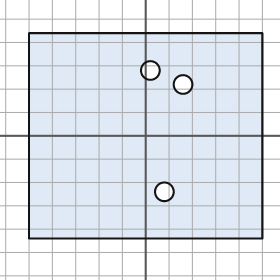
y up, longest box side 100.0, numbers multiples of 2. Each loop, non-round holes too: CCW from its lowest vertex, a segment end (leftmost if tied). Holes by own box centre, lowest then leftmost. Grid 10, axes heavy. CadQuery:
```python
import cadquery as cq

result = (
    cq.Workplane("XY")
    .moveTo(-50.0, -44.0)
    .lineTo(50.0, -44.0)
    .lineTo(50.0, 44.0)
    .lineTo(-50.0, 44.0)
    .close()
    .moveTo(8.0, -24.0)
    .circle(4.0)
    .moveTo(16.0, 22.0)
    .circle(4.0)
    .moveTo(2.0, 28.0)
    .circle(4.0)
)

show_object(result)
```